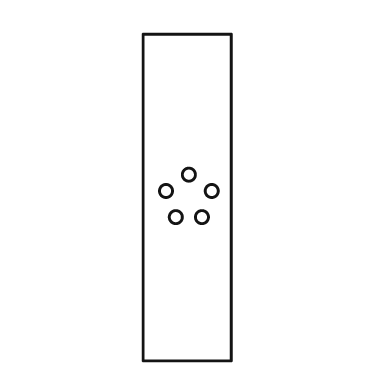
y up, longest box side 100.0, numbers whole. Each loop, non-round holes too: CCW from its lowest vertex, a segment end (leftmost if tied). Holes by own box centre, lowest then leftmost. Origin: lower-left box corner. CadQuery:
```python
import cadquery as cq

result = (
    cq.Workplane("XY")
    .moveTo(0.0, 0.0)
    .lineTo(27.0, 0.0)
    .lineTo(27.0, 100.0)
    .lineTo(0.0, 100.0)
    .close()
    .moveTo(10.0, 44.0)
    .circle(2.0)
    .moveTo(18.0, 44.0)
    .circle(2.0)
    .moveTo(7.0, 52.0)
    .circle(2.0)
    .moveTo(21.0, 52.0)
    .circle(2.0)
    .moveTo(14.0, 57.0)
    .circle(2.0)
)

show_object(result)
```